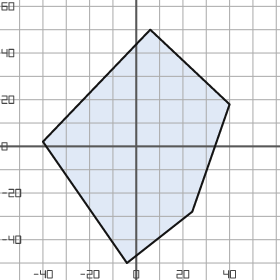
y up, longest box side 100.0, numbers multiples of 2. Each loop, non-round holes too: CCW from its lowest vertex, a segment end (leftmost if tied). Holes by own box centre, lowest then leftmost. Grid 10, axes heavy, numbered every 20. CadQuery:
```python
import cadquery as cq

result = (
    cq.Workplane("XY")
    .moveTo(-4.0, -50.0)
    .lineTo(24.0, -28.0)
    .lineTo(40.0, 18.0)
    .lineTo(6.0, 50.0)
    .lineTo(-40.0, 2.0)
    .close()
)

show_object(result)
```